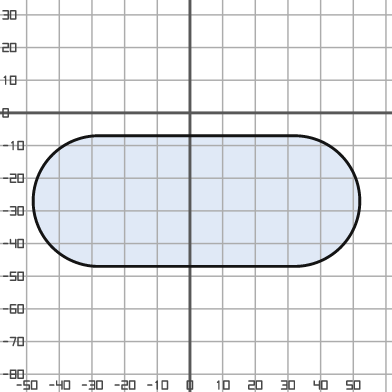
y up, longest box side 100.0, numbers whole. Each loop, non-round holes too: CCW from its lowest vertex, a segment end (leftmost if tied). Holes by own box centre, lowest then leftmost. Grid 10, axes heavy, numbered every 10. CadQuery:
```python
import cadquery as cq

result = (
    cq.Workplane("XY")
    .moveTo(-28.0, -47.0)
    .lineTo(32.0, -47.0)
    .threePointArc((52.0, -27.0), (32.0, -7.0))
    .lineTo(-28.0, -7.0)
    .threePointArc((-48.0, -27.0), (-28.0, -47.0))
    .close()
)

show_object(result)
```